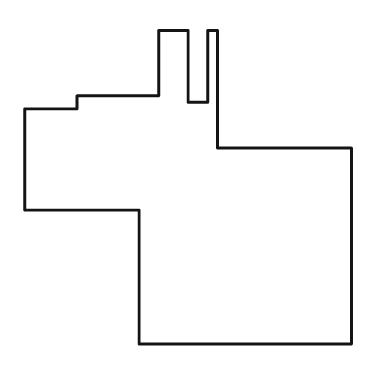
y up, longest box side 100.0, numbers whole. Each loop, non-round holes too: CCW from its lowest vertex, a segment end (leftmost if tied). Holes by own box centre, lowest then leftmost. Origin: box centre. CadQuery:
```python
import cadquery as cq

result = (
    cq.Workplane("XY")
    .moveTo(-15.0, -48.0)
    .lineTo(50.0, -48.0)
    .lineTo(50.0, 12.0)
    .lineTo(9.0, 12.0)
    .lineTo(9.0, 48.0)
    .lineTo(6.0, 48.0)
    .lineTo(6.0, 26.0)
    .lineTo(0.0, 26.0)
    .lineTo(0.0, 48.0)
    .lineTo(-9.0, 48.0)
    .lineTo(-9.0, 28.0)
    .lineTo(-34.0, 28.0)
    .lineTo(-34.0, 24.0)
    .lineTo(-50.0, 24.0)
    .lineTo(-50.0, -7.0)
    .lineTo(-15.0, -7.0)
    .close()
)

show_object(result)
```